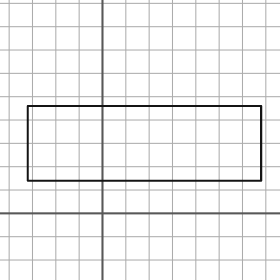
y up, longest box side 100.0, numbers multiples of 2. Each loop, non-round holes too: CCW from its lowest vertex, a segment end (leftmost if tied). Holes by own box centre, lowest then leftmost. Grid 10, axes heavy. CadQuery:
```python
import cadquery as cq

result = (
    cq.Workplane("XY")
    .moveTo(-32.0, 14.0)
    .lineTo(68.0, 14.0)
    .lineTo(68.0, 46.0)
    .lineTo(-32.0, 46.0)
    .close()
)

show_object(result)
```